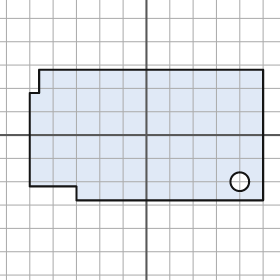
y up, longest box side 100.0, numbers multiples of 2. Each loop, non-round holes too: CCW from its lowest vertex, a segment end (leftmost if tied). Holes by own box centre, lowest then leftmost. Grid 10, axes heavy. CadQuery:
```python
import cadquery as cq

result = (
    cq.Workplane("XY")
    .moveTo(-30.0, -28.0)
    .lineTo(50.0, -28.0)
    .lineTo(50.0, 28.0)
    .lineTo(-46.0, 28.0)
    .lineTo(-46.0, 18.0)
    .lineTo(-50.0, 18.0)
    .lineTo(-50.0, -22.0)
    .lineTo(-30.0, -22.0)
    .close()
    .moveTo(40.0, -20.0)
    .circle(4.0)
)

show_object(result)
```